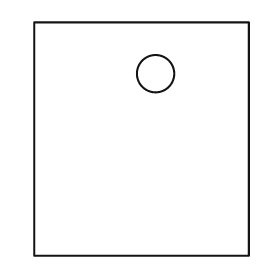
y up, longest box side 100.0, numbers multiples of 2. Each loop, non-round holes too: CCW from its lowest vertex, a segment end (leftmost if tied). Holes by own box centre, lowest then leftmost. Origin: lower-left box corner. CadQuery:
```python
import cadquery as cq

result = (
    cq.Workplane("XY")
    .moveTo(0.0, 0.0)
    .lineTo(92.0, 0.0)
    .lineTo(92.0, 100.0)
    .lineTo(0.0, 100.0)
    .close()
    .moveTo(52.0, 78.0)
    .circle(8.0)
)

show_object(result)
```